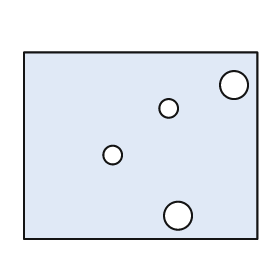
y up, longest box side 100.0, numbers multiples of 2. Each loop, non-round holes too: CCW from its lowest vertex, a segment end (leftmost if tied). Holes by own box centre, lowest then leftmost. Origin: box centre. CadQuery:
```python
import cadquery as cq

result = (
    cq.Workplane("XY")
    .moveTo(-50.0, -40.0)
    .lineTo(50.0, -40.0)
    .lineTo(50.0, 40.0)
    .lineTo(-50.0, 40.0)
    .close()
    .moveTo(16.0, -30.0)
    .circle(6.0)
    .moveTo(-12.0, -4.0)
    .circle(4.0)
    .moveTo(12.0, 16.0)
    .circle(4.0)
    .moveTo(40.0, 26.0)
    .circle(6.0)
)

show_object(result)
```